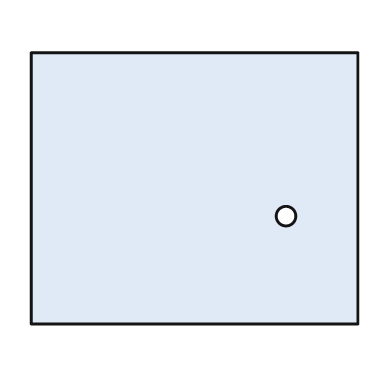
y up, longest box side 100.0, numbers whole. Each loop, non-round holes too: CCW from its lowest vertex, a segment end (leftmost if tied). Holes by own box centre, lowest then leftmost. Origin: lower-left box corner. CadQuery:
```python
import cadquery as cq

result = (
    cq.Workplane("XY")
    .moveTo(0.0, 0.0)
    .lineTo(100.0, 0.0)
    .lineTo(100.0, 83.0)
    .lineTo(0.0, 83.0)
    .close()
    .moveTo(78.0, 33.0)
    .circle(3.0)
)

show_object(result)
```